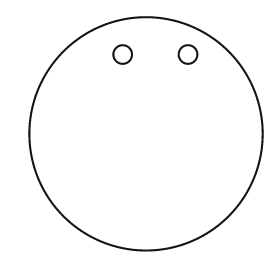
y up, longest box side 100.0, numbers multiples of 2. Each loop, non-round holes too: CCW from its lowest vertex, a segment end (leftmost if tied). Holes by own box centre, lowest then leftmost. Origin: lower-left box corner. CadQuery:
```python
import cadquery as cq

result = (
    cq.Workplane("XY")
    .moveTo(50.0, 50.0)
    .circle(50.0)
    .moveTo(40.0, 84.0)
    .circle(4.0)
    .moveTo(68.0, 84.0)
    .circle(4.0)
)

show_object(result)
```